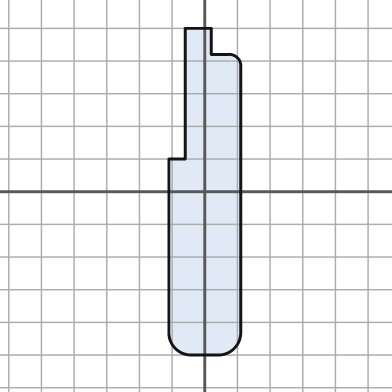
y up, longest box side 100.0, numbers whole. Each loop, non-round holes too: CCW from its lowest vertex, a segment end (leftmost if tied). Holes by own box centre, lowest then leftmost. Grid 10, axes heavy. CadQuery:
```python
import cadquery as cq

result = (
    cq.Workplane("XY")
    .moveTo(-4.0, -50.0)
    .lineTo(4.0, -50.0)
    .threePointArc((9.0, -48.0), (11.0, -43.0))
    .lineTo(11.0, 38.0)
    .threePointArc((10.0, 41.0), (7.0, 42.0))
    .lineTo(2.0, 42.0)
    .lineTo(2.0, 50.0)
    .lineTo(-6.0, 50.0)
    .lineTo(-6.0, 10.0)
    .lineTo(-11.0, 10.0)
    .lineTo(-11.0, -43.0)
    .threePointArc((-9.0, -48.0), (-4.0, -50.0))
    .close()
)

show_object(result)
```